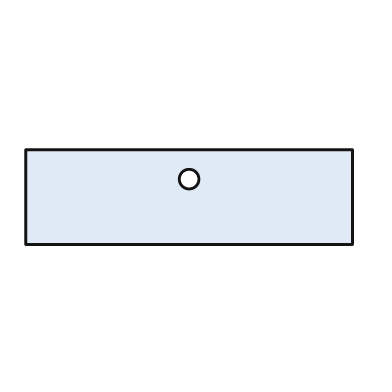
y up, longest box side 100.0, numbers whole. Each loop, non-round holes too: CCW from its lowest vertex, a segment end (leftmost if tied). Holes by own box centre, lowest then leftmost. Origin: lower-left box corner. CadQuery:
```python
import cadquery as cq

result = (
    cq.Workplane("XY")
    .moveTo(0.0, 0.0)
    .lineTo(100.0, 0.0)
    .lineTo(100.0, 29.0)
    .lineTo(0.0, 29.0)
    .close()
    .moveTo(50.0, 20.0)
    .circle(3.0)
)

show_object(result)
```